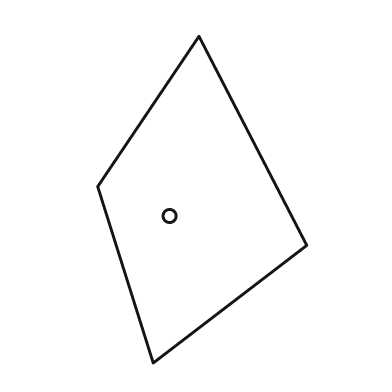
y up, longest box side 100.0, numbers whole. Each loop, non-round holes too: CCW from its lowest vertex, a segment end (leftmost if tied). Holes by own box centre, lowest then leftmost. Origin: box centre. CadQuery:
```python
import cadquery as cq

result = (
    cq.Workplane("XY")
    .moveTo(-15.0, -50.0)
    .lineTo(32.0, -14.0)
    .lineTo(-1.0, 50.0)
    .lineTo(-32.0, 4.0)
    .close()
    .moveTo(-10.0, -5.0)
    .circle(2.0)
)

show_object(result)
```